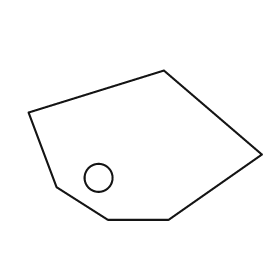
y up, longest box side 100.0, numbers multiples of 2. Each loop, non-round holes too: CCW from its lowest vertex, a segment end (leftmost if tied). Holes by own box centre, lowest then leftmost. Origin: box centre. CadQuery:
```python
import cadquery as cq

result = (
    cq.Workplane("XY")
    .moveTo(-16.0, -32.0)
    .lineTo(10.0, -32.0)
    .lineTo(50.0, -4.0)
    .lineTo(8.0, 32.0)
    .lineTo(-50.0, 14.0)
    .lineTo(-38.0, -18.0)
    .close()
    .moveTo(-20.0, -14.0)
    .circle(6.0)
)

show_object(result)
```